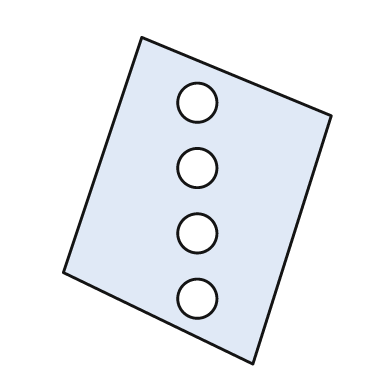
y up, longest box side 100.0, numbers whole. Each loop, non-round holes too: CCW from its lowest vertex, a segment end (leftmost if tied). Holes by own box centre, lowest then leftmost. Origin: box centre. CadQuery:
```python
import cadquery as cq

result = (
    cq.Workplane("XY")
    .moveTo(17.0, -50.0)
    .lineTo(41.0, 26.0)
    .lineTo(-17.0, 50.0)
    .lineTo(-41.0, -22.0)
    .close()
    .moveTo(0.0, -30.0)
    .circle(6.0)
    .moveTo(0.0, -10.0)
    .circle(6.0)
    .moveTo(0.0, 10.0)
    .circle(6.0)
    .moveTo(0.0, 30.0)
    .circle(6.0)
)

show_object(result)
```